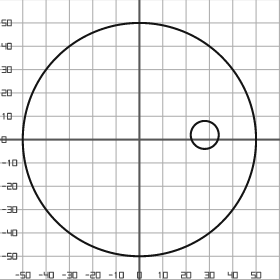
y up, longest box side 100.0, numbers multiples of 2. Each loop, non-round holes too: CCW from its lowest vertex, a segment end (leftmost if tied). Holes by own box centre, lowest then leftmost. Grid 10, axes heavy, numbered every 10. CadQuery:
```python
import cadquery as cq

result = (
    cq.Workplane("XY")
    .moveTo(0.0, 0.0)
    .circle(50.0)
    .moveTo(28.0, 2.0)
    .circle(6.0)
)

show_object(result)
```